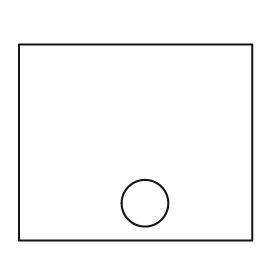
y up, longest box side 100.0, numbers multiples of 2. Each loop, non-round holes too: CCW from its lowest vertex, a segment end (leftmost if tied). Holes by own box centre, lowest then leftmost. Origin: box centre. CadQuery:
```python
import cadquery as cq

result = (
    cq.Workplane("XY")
    .moveTo(-50.0, -42.0)
    .lineTo(50.0, -42.0)
    .lineTo(50.0, 42.0)
    .lineTo(-50.0, 42.0)
    .close()
    .moveTo(4.0, -26.0)
    .circle(10.0)
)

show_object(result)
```